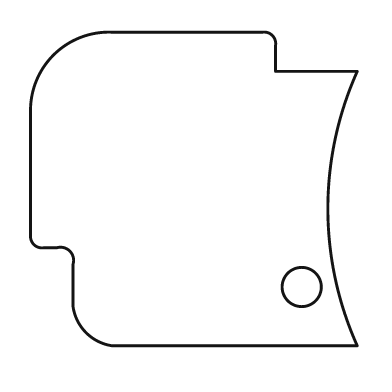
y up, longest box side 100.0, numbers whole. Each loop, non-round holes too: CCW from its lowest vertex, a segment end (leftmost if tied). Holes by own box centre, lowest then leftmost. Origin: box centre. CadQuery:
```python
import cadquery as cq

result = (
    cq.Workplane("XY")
    .moveTo(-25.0, -48.0)
    .lineTo(50.0, -48.0)
    .threePointArc((41.0, -6.0), (50.0, 36.0))
    .lineTo(25.0, 36.0)
    .lineTo(25.0, 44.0)
    .threePointArc((24.0, 47.0), (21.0, 48.0))
    .lineTo(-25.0, 48.0)
    .threePointArc((-43.0, 41.0), (-50.0, 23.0))
    .lineTo(-50.0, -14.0)
    .threePointArc((-49.0, -17.0), (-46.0, -18.0))
    .lineTo(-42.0, -18.0)
    .threePointArc((-38.0, -19.0), (-37.0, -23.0))
    .lineTo(-37.0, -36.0)
    .threePointArc((-33.0, -44.0), (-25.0, -48.0))
    .close()
    .moveTo(33.0, -30.0)
    .circle(6.0)
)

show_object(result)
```